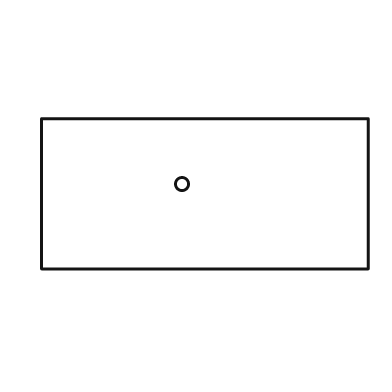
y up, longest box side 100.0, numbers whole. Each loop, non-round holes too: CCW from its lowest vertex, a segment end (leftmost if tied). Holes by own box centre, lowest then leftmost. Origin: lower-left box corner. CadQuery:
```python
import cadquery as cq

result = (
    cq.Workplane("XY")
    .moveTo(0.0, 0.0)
    .lineTo(100.0, 0.0)
    .lineTo(100.0, 46.0)
    .lineTo(0.0, 46.0)
    .close()
    .moveTo(43.0, 26.0)
    .circle(2.0)
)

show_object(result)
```